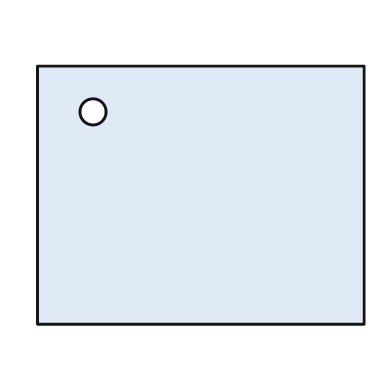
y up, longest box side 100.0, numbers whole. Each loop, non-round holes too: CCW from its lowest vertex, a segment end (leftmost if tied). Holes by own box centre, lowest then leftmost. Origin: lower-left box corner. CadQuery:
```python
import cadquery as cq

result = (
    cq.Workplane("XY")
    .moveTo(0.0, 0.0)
    .lineTo(100.0, 0.0)
    .lineTo(100.0, 79.0)
    .lineTo(0.0, 79.0)
    .close()
    .moveTo(17.0, 65.0)
    .circle(4.0)
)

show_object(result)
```